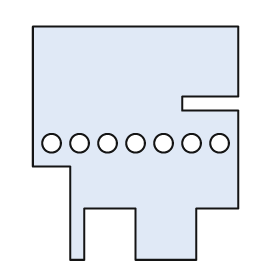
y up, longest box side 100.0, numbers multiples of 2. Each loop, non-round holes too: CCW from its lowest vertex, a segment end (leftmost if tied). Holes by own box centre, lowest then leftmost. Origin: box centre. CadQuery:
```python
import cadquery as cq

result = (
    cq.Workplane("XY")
    .moveTo(-28.0, -50.0)
    .lineTo(-22.0, -50.0)
    .lineTo(-22.0, -28.0)
    .lineTo(0.0, -28.0)
    .lineTo(0.0, -50.0)
    .lineTo(26.0, -50.0)
    .lineTo(26.0, -28.0)
    .lineTo(44.0, -28.0)
    .lineTo(44.0, 14.0)
    .lineTo(20.0, 14.0)
    .lineTo(20.0, 20.0)
    .lineTo(44.0, 20.0)
    .lineTo(44.0, 50.0)
    .lineTo(-44.0, 50.0)
    .lineTo(-44.0, -10.0)
    .lineTo(-28.0, -10.0)
    .close()
    .moveTo(-36.0, 0.0)
    .circle(4.0)
    .moveTo(-24.0, 0.0)
    .circle(4.0)
    .moveTo(-12.0, 0.0)
    .circle(4.0)
    .moveTo(0.0, 0.0)
    .circle(4.0)
    .moveTo(12.0, 0.0)
    .circle(4.0)
    .moveTo(24.0, 0.0)
    .circle(4.0)
    .moveTo(36.0, 0.0)
    .circle(4.0)
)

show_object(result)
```